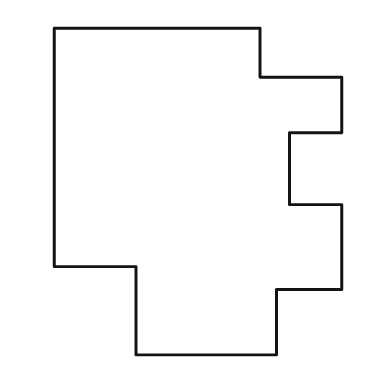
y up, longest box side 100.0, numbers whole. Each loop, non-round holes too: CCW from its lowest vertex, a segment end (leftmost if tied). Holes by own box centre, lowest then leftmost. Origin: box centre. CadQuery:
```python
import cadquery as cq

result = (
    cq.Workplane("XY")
    .moveTo(-19.0, -50.0)
    .lineTo(24.0, -50.0)
    .lineTo(24.0, -30.0)
    .lineTo(44.0, -30.0)
    .lineTo(44.0, -4.0)
    .lineTo(28.0, -4.0)
    .lineTo(28.0, 18.0)
    .lineTo(44.0, 18.0)
    .lineTo(44.0, 35.0)
    .lineTo(19.0, 35.0)
    .lineTo(19.0, 50.0)
    .lineTo(-44.0, 50.0)
    .lineTo(-44.0, -23.0)
    .lineTo(-19.0, -23.0)
    .close()
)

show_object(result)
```